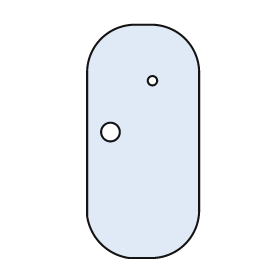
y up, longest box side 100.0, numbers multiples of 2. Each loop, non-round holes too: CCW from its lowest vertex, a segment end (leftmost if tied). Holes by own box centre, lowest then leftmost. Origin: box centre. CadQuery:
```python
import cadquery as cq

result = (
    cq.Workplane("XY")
    .moveTo(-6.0, -50.0)
    .lineTo(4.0, -50.0)
    .threePointArc((18.0, -44.0), (24.0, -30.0))
    .lineTo(24.0, 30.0)
    .threePointArc((18.0, 44.0), (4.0, 50.0))
    .lineTo(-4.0, 50.0)
    .threePointArc((-18.0, 44.0), (-24.0, 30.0))
    .lineTo(-24.0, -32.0)
    .threePointArc((-18.0, -44.0), (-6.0, -50.0))
    .close()
    .moveTo(-14.0, 4.0)
    .circle(4.0)
    .moveTo(4.0, 26.0)
    .circle(2.0)
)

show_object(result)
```